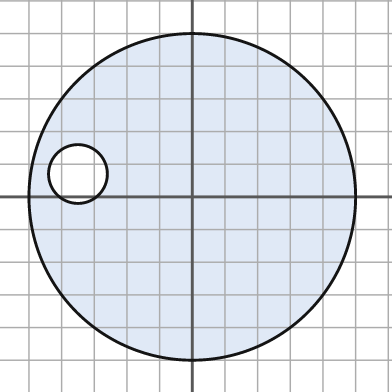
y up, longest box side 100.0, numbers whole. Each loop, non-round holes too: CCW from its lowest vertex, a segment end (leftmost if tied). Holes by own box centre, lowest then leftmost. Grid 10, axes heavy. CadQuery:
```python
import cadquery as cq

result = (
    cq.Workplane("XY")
    .moveTo(0.0, 0.0)
    .circle(50.0)
    .moveTo(-35.0, 7.0)
    .circle(9.0)
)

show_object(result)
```